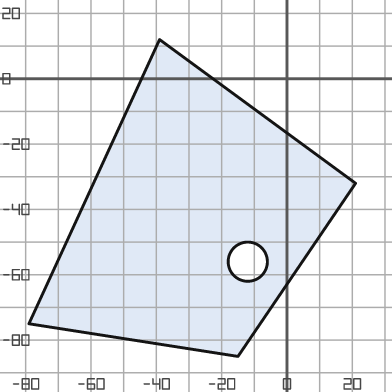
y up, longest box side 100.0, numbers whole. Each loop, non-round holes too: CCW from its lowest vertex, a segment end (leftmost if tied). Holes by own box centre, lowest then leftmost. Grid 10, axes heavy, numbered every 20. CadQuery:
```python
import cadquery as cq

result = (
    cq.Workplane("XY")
    .moveTo(-15.0, -85.0)
    .lineTo(21.0, -32.0)
    .lineTo(-39.0, 12.0)
    .lineTo(-79.0, -75.0)
    .close()
    .moveTo(-12.0, -56.0)
    .circle(6.0)
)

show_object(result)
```